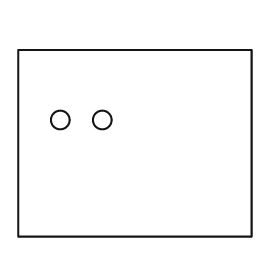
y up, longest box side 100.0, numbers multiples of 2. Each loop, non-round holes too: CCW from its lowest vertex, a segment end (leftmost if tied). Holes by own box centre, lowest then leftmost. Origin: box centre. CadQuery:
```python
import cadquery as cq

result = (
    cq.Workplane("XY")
    .moveTo(-50.0, -40.0)
    .lineTo(50.0, -40.0)
    .lineTo(50.0, 40.0)
    .lineTo(-50.0, 40.0)
    .close()
    .moveTo(-32.0, 10.0)
    .circle(4.0)
    .moveTo(-14.0, 10.0)
    .circle(4.0)
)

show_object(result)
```